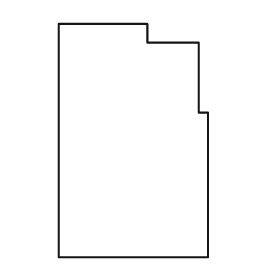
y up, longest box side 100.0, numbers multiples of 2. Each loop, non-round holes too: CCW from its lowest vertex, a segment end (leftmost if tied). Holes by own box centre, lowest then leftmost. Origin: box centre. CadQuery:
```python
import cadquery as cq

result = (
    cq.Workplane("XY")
    .moveTo(-32.0, -50.0)
    .lineTo(32.0, -50.0)
    .lineTo(32.0, 12.0)
    .lineTo(28.0, 12.0)
    .lineTo(28.0, 42.0)
    .lineTo(6.0, 42.0)
    .lineTo(6.0, 50.0)
    .lineTo(-32.0, 50.0)
    .close()
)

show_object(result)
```